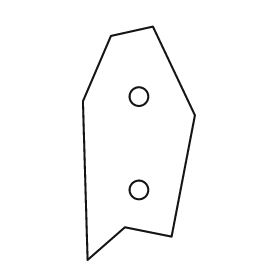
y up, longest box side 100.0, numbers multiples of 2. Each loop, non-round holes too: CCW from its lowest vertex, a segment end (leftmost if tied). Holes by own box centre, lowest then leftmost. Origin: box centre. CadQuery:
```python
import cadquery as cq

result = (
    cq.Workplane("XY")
    .moveTo(-22.0, -50.0)
    .lineTo(-6.0, -36.0)
    .lineTo(14.0, -40.0)
    .lineTo(24.0, 12.0)
    .lineTo(6.0, 50.0)
    .lineTo(-12.0, 46.0)
    .lineTo(-24.0, 18.0)
    .close()
    .moveTo(0.0, -20.0)
    .circle(4.0)
    .moveTo(0.0, 20.0)
    .circle(4.0)
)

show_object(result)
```